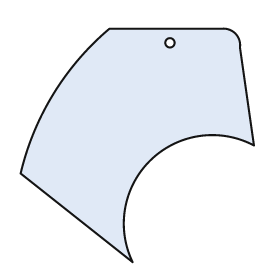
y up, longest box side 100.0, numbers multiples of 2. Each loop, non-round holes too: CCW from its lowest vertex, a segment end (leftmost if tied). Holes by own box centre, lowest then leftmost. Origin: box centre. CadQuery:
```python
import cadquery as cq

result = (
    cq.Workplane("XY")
    .moveTo(-2.0, -50.0)
    .threePointArc((6.0, -6.0), (50.0, 0.0))
    .lineTo(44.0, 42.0)
    .threePointArc((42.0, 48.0), (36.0, 50.0))
    .lineTo(-12.0, 50.0)
    .threePointArc((-36.0, 22.0), (-50.0, -12.0))
    .close()
    .moveTo(14.0, 44.0)
    .circle(2.0)
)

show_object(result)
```